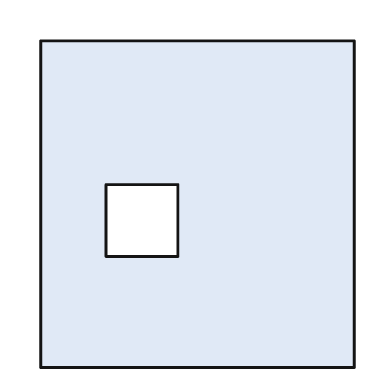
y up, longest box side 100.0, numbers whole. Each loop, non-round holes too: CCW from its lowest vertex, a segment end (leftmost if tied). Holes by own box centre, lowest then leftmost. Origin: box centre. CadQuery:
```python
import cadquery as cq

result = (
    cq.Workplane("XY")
    .moveTo(-48.0, -50.0)
    .lineTo(48.0, -50.0)
    .lineTo(48.0, 50.0)
    .lineTo(-48.0, 50.0)
    .close()
    .moveTo(-28.0, -16.0)
    .lineTo(-6.0, -16.0)
    .lineTo(-6.0, 6.0)
    .lineTo(-28.0, 6.0)
    .close()
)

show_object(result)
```